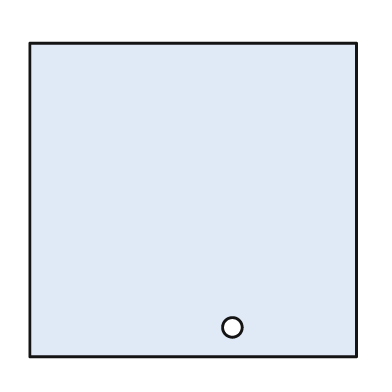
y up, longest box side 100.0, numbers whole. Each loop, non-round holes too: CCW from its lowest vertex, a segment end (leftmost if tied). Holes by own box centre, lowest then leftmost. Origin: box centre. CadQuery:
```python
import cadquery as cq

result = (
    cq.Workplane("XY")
    .moveTo(-50.0, -48.0)
    .lineTo(50.0, -48.0)
    .lineTo(50.0, 48.0)
    .lineTo(-50.0, 48.0)
    .close()
    .moveTo(12.0, -39.0)
    .circle(3.0)
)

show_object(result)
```